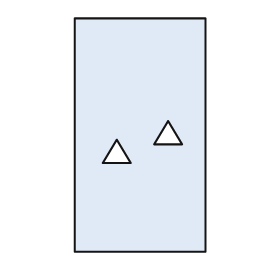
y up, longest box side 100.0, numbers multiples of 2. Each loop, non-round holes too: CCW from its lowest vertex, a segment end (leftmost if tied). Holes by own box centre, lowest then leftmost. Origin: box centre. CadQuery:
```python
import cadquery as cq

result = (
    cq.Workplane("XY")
    .moveTo(-28.0, -50.0)
    .lineTo(28.0, -50.0)
    .lineTo(28.0, 50.0)
    .lineTo(-28.0, 50.0)
    .close()
    .moveTo(-16.0, -12.0)
    .lineTo(-4.0, -12.0)
    .lineTo(-10.0, -2.0)
    .close()
    .moveTo(6.0, -4.0)
    .lineTo(18.0, -4.0)
    .lineTo(12.0, 6.0)
    .close()
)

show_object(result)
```